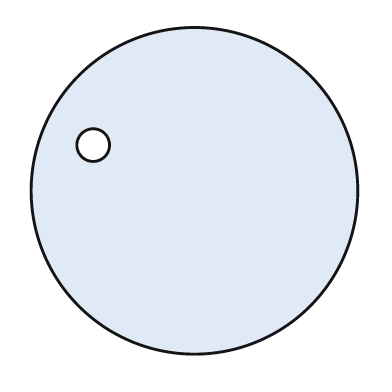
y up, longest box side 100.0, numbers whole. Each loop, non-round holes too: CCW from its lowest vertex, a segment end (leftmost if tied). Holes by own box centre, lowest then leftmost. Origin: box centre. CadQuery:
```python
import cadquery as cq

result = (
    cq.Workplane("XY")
    .moveTo(0.0, 0.0)
    .circle(50.0)
    .moveTo(-31.0, 14.0)
    .circle(5.0)
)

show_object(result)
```